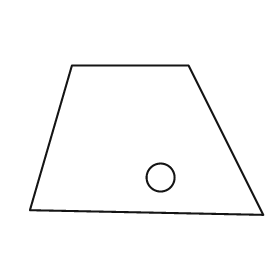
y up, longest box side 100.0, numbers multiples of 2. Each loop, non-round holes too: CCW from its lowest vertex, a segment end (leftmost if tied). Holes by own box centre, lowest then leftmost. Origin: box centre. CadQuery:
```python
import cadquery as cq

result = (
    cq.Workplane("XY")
    .moveTo(50.0, -32.0)
    .lineTo(18.0, 32.0)
    .lineTo(-32.0, 32.0)
    .lineTo(-50.0, -30.0)
    .close()
    .moveTo(6.0, -16.0)
    .circle(6.0)
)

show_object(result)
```